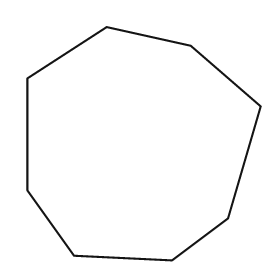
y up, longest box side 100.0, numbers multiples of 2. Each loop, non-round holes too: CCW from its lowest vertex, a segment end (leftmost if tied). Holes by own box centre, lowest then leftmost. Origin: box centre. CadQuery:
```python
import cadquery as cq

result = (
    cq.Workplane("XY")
    .moveTo(12.0, -50.0)
    .lineTo(36.0, -32.0)
    .lineTo(50.0, 16.0)
    .lineTo(20.0, 42.0)
    .lineTo(-16.0, 50.0)
    .lineTo(-50.0, 28.0)
    .lineTo(-50.0, -20.0)
    .lineTo(-30.0, -48.0)
    .close()
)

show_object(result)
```